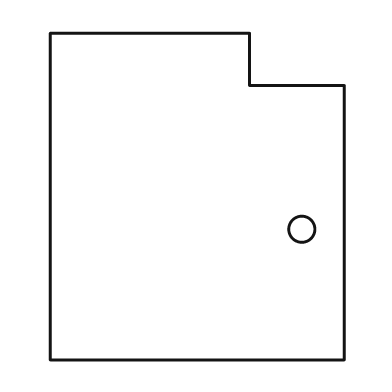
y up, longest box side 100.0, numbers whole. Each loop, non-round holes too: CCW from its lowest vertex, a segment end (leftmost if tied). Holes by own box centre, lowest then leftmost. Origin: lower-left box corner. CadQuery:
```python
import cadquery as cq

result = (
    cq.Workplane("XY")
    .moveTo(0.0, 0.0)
    .lineTo(90.0, 0.0)
    .lineTo(90.0, 84.0)
    .lineTo(61.0, 84.0)
    .lineTo(61.0, 100.0)
    .lineTo(0.0, 100.0)
    .close()
    .moveTo(77.0, 40.0)
    .circle(4.0)
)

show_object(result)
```